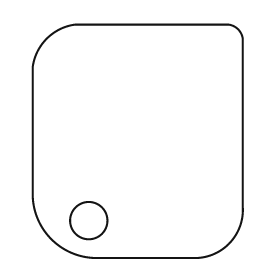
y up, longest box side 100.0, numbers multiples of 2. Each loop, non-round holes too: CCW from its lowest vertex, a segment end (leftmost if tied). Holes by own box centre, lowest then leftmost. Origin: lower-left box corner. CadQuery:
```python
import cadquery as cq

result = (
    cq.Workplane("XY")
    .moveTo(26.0, 0.0)
    .lineTo(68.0, 0.0)
    .threePointArc((84.0, 6.0), (90.0, 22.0))
    .lineTo(90.0, 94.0)
    .threePointArc((88.0, 98.0), (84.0, 100.0))
    .lineTo(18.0, 100.0)
    .threePointArc((6.0, 94.0), (0.0, 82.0))
    .lineTo(0.0, 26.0)
    .threePointArc((8.0, 8.0), (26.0, 0.0))
    .close()
    .moveTo(24.0, 16.0)
    .circle(8.0)
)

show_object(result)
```